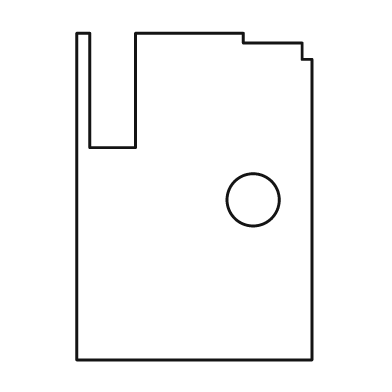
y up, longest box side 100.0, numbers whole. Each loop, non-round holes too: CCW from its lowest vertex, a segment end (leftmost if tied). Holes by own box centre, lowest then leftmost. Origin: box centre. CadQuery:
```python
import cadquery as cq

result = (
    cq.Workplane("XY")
    .moveTo(-36.0, -50.0)
    .lineTo(36.0, -50.0)
    .lineTo(36.0, 42.0)
    .lineTo(33.0, 42.0)
    .lineTo(33.0, 47.0)
    .lineTo(15.0, 47.0)
    .lineTo(15.0, 50.0)
    .lineTo(-18.0, 50.0)
    .lineTo(-18.0, 15.0)
    .lineTo(-32.0, 15.0)
    .lineTo(-32.0, 50.0)
    .lineTo(-36.0, 50.0)
    .close()
    .moveTo(18.0, -1.0)
    .circle(8.0)
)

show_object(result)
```